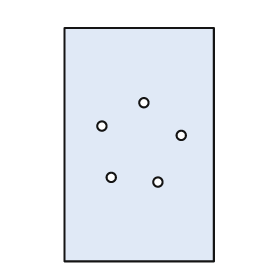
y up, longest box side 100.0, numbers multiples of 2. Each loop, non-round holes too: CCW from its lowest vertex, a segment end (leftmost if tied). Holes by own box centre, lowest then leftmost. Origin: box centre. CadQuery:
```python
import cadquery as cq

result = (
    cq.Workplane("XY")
    .moveTo(-32.0, -50.0)
    .lineTo(32.0, -50.0)
    .lineTo(32.0, 50.0)
    .lineTo(-32.0, 50.0)
    .close()
    .moveTo(8.0, -16.0)
    .circle(2.0)
    .moveTo(-12.0, -14.0)
    .circle(2.0)
    .moveTo(18.0, 4.0)
    .circle(2.0)
    .moveTo(-16.0, 8.0)
    .circle(2.0)
    .moveTo(2.0, 18.0)
    .circle(2.0)
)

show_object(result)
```